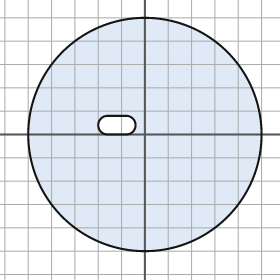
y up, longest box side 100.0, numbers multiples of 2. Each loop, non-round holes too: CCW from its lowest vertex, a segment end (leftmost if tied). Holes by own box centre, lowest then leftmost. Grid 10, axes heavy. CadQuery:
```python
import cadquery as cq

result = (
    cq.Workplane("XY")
    .moveTo(0.0, 0.0)
    .circle(50.0)
    .moveTo(-16.0, 0.0)
    .lineTo(-8.0, 0.0)
    .threePointArc((-4.0, 4.0), (-8.0, 8.0))
    .lineTo(-16.0, 8.0)
    .threePointArc((-20.0, 4.0), (-16.0, 0.0))
    .close()
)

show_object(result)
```